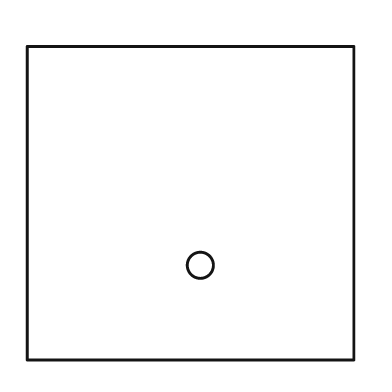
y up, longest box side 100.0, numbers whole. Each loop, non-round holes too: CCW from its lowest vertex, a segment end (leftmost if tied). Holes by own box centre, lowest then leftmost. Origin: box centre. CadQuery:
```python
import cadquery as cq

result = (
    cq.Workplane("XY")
    .moveTo(-50.0, -48.0)
    .lineTo(50.0, -48.0)
    .lineTo(50.0, 48.0)
    .lineTo(-50.0, 48.0)
    .close()
    .moveTo(3.0, -19.0)
    .circle(4.0)
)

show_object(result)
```